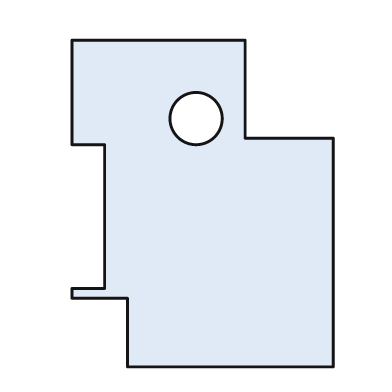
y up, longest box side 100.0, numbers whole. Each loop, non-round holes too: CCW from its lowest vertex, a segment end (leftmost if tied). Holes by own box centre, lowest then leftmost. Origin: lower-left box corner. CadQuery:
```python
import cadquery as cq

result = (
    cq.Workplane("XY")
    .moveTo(17.0, 0.0)
    .lineTo(80.0, 0.0)
    .lineTo(80.0, 70.0)
    .lineTo(53.0, 70.0)
    .lineTo(53.0, 100.0)
    .lineTo(0.0, 100.0)
    .lineTo(0.0, 68.0)
    .lineTo(10.0, 68.0)
    .lineTo(10.0, 24.0)
    .lineTo(0.0, 24.0)
    .lineTo(0.0, 21.0)
    .lineTo(17.0, 21.0)
    .close()
    .moveTo(38.0, 76.0)
    .circle(8.0)
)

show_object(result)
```